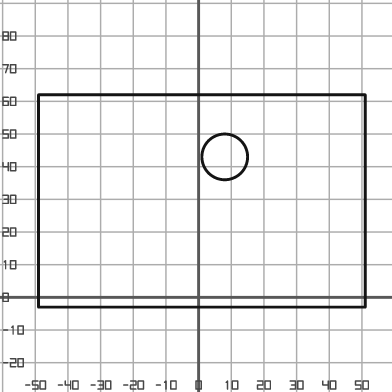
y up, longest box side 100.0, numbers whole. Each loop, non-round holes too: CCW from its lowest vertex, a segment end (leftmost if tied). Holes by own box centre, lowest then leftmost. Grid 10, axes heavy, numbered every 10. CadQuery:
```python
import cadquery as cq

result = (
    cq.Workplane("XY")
    .moveTo(-49.0, -3.0)
    .lineTo(51.0, -3.0)
    .lineTo(51.0, 62.0)
    .lineTo(-49.0, 62.0)
    .close()
    .moveTo(8.0, 43.0)
    .circle(7.0)
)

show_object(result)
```